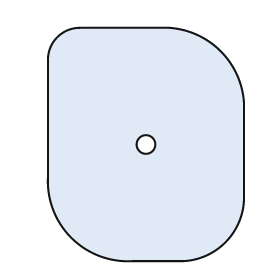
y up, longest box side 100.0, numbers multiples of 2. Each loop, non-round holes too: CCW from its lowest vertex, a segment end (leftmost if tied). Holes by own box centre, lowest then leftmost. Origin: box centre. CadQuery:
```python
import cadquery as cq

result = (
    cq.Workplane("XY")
    .moveTo(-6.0, -50.0)
    .lineTo(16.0, -50.0)
    .threePointArc((34.0, -42.0), (42.0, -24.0))
    .lineTo(42.0, 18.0)
    .threePointArc((32.0, 40.0), (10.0, 50.0))
    .lineTo(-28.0, 50.0)
    .threePointArc((-38.0, 46.0), (-42.0, 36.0))
    .lineTo(-42.0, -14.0)
    .threePointArc((-32.0, -40.0), (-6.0, -50.0))
    .close()
    .moveTo(0.0, 0.0)
    .circle(4.0)
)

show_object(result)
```